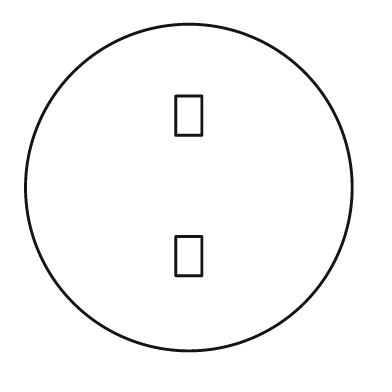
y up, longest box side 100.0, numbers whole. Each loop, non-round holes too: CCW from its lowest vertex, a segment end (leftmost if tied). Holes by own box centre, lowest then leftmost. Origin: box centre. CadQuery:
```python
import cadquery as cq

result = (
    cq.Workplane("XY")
    .moveTo(0.0, 0.0)
    .circle(50.0)
    .moveTo(-4.0, -27.0)
    .lineTo(4.0, -27.0)
    .lineTo(4.0, -15.0)
    .lineTo(-4.0, -15.0)
    .close()
    .moveTo(-4.0, 16.0)
    .lineTo(4.0, 16.0)
    .lineTo(4.0, 28.0)
    .lineTo(-4.0, 28.0)
    .close()
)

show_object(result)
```